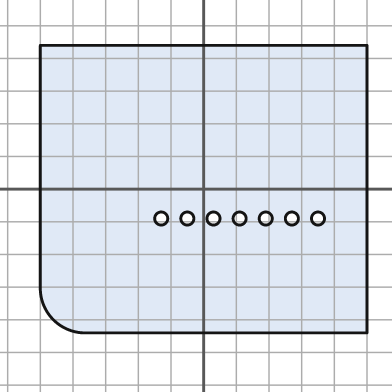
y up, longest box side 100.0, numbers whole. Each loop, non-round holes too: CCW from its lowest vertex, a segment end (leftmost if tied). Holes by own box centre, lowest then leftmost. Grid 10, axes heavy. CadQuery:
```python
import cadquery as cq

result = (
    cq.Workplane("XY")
    .moveTo(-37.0, -44.0)
    .lineTo(50.0, -44.0)
    .lineTo(50.0, 44.0)
    .lineTo(-50.0, 44.0)
    .lineTo(-50.0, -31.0)
    .threePointArc((-46.0, -40.0), (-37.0, -44.0))
    .close()
    .moveTo(-13.0, -9.0)
    .circle(2.0)
    .moveTo(-5.0, -9.0)
    .circle(2.0)
    .moveTo(3.0, -9.0)
    .circle(2.0)
    .moveTo(11.0, -9.0)
    .circle(2.0)
    .moveTo(19.0, -9.0)
    .circle(2.0)
    .moveTo(27.0, -9.0)
    .circle(2.0)
    .moveTo(35.0, -9.0)
    .circle(2.0)
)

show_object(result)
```